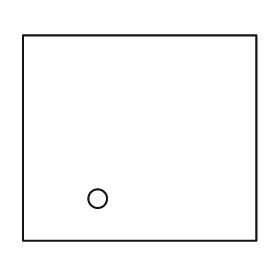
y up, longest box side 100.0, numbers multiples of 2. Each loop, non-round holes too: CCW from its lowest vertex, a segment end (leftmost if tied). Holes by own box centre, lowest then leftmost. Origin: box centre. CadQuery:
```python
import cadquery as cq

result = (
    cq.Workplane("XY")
    .moveTo(-50.0, -44.0)
    .lineTo(50.0, -44.0)
    .lineTo(50.0, 44.0)
    .lineTo(-50.0, 44.0)
    .close()
    .moveTo(-18.0, -26.0)
    .circle(4.0)
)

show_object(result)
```